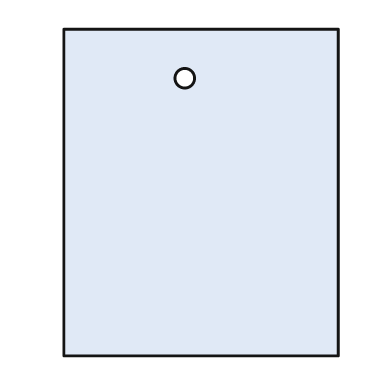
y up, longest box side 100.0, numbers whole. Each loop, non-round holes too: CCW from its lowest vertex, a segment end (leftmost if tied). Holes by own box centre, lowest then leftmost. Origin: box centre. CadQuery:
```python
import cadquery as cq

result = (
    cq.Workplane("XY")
    .moveTo(-42.0, -50.0)
    .lineTo(42.0, -50.0)
    .lineTo(42.0, 50.0)
    .lineTo(-42.0, 50.0)
    .close()
    .moveTo(-5.0, 35.0)
    .circle(3.0)
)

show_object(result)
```